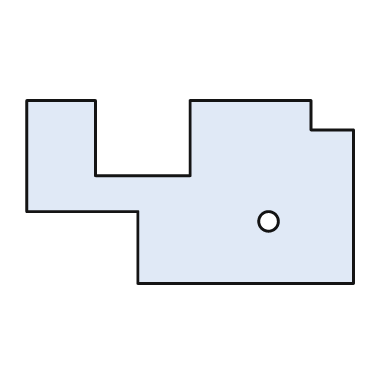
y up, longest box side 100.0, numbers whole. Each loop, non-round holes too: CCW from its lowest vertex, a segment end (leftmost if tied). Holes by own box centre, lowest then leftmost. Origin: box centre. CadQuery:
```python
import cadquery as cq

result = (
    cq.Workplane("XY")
    .moveTo(-16.0, -28.0)
    .lineTo(50.0, -28.0)
    .lineTo(50.0, 19.0)
    .lineTo(37.0, 19.0)
    .lineTo(37.0, 28.0)
    .lineTo(0.0, 28.0)
    .lineTo(0.0, 5.0)
    .lineTo(-29.0, 5.0)
    .lineTo(-29.0, 28.0)
    .lineTo(-50.0, 28.0)
    .lineTo(-50.0, -6.0)
    .lineTo(-16.0, -6.0)
    .close()
    .moveTo(24.0, -9.0)
    .circle(3.0)
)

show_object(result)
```